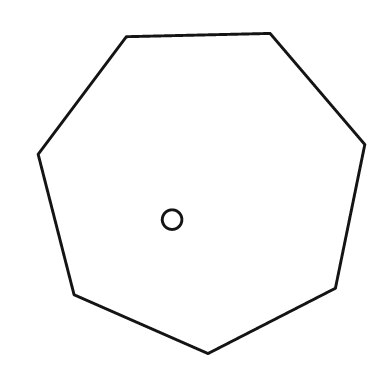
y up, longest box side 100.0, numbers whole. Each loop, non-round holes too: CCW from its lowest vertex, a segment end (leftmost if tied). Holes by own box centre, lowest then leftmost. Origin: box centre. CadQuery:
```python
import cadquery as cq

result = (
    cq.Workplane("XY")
    .moveTo(2.0, -49.0)
    .lineTo(41.0, -29.0)
    .lineTo(50.0, 15.0)
    .lineTo(21.0, 49.0)
    .lineTo(-23.0, 48.0)
    .lineTo(-50.0, 12.0)
    .lineTo(-39.0, -31.0)
    .close()
    .moveTo(-9.0, -8.0)
    .circle(3.0)
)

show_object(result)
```